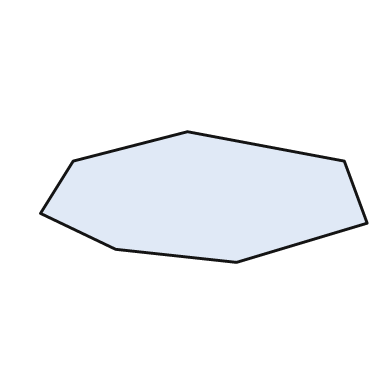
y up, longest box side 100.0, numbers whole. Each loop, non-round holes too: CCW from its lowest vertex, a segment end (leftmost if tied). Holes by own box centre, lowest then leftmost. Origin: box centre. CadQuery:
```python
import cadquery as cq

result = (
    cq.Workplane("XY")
    .moveTo(10.0, -20.0)
    .lineTo(50.0, -8.0)
    .lineTo(43.0, 11.0)
    .lineTo(-5.0, 20.0)
    .lineTo(-40.0, 11.0)
    .lineTo(-50.0, -5.0)
    .lineTo(-27.0, -16.0)
    .close()
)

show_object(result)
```